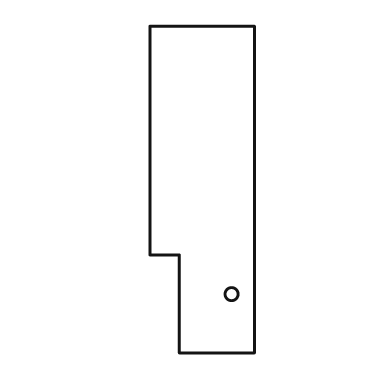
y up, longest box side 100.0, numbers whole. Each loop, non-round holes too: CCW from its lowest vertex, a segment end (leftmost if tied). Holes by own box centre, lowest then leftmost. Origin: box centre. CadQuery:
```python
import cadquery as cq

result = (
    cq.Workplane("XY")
    .moveTo(-7.0, -50.0)
    .lineTo(16.0, -50.0)
    .lineTo(16.0, 50.0)
    .lineTo(-16.0, 50.0)
    .lineTo(-16.0, -20.0)
    .lineTo(-7.0, -20.0)
    .close()
    .moveTo(9.0, -32.0)
    .circle(2.0)
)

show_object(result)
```